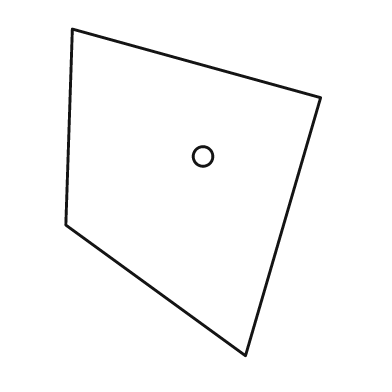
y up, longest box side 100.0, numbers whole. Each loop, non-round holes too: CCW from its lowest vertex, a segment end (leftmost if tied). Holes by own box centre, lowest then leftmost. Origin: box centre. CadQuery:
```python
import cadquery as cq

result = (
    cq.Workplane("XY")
    .moveTo(16.0, -50.0)
    .lineTo(39.0, 29.0)
    .lineTo(-37.0, 50.0)
    .lineTo(-39.0, -10.0)
    .close()
    .moveTo(3.0, 11.0)
    .circle(3.0)
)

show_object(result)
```